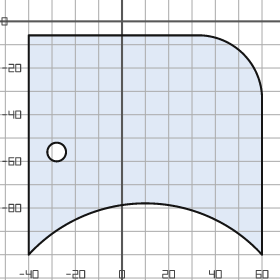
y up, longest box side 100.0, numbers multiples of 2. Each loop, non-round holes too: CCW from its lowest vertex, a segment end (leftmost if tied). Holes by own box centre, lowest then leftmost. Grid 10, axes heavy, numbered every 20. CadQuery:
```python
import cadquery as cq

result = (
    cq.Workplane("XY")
    .moveTo(-40.0, -100.0)
    .threePointArc((10.0, -78.0), (60.0, -100.0))
    .lineTo(60.0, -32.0)
    .threePointArc((52.0, -14.0), (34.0, -6.0))
    .lineTo(-40.0, -6.0)
    .close()
    .moveTo(-28.0, -56.0)
    .circle(4.0)
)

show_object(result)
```